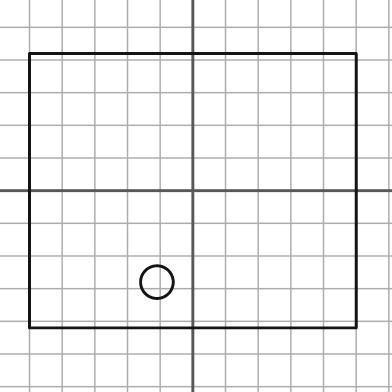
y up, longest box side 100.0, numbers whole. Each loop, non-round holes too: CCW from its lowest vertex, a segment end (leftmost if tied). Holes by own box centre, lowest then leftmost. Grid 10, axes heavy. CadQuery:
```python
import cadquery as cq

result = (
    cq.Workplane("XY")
    .moveTo(-50.0, -42.0)
    .lineTo(50.0, -42.0)
    .lineTo(50.0, 42.0)
    .lineTo(-50.0, 42.0)
    .close()
    .moveTo(-11.0, -28.0)
    .circle(5.0)
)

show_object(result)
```